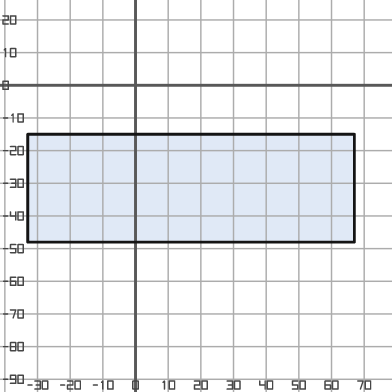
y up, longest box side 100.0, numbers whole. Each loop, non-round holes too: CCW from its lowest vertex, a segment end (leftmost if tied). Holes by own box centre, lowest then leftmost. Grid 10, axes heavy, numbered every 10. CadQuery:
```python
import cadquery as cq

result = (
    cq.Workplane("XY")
    .moveTo(-33.0, -48.0)
    .lineTo(67.0, -48.0)
    .lineTo(67.0, -15.0)
    .lineTo(-33.0, -15.0)
    .close()
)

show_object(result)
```